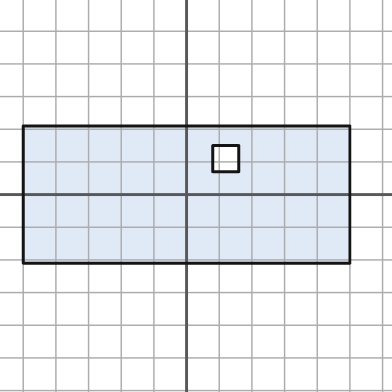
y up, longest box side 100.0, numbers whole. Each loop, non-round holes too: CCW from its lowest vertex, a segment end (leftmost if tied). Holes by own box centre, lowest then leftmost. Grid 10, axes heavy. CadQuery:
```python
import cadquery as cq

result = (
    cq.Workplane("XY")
    .moveTo(-50.0, -21.0)
    .lineTo(50.0, -21.0)
    .lineTo(50.0, 21.0)
    .lineTo(-50.0, 21.0)
    .close()
    .moveTo(8.0, 7.0)
    .lineTo(16.0, 7.0)
    .lineTo(16.0, 15.0)
    .lineTo(8.0, 15.0)
    .close()
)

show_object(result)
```